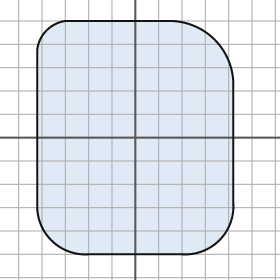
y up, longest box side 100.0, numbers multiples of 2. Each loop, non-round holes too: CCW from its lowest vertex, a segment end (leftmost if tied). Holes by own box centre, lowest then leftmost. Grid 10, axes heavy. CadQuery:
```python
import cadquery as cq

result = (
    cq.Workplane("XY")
    .moveTo(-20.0, -50.0)
    .lineTo(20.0, -50.0)
    .threePointArc((36.0, -44.0), (42.0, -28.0))
    .lineTo(42.0, 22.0)
    .threePointArc((34.0, 42.0), (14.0, 50.0))
    .lineTo(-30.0, 50.0)
    .threePointArc((-38.0, 46.0), (-42.0, 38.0))
    .lineTo(-42.0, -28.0)
    .threePointArc((-36.0, -44.0), (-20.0, -50.0))
    .close()
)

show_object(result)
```